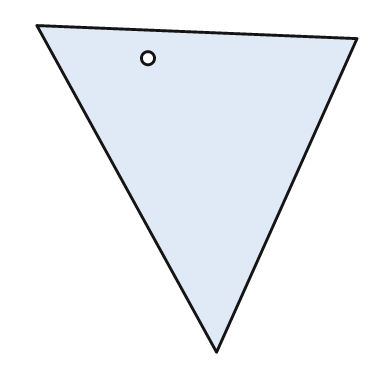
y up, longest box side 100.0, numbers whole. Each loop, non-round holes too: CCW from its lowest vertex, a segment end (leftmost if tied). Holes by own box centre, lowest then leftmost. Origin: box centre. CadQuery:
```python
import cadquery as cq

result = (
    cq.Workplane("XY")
    .moveTo(6.0, -50.0)
    .lineTo(49.0, 46.0)
    .lineTo(-49.0, 50.0)
    .close()
    .moveTo(-15.0, 40.0)
    .circle(2.0)
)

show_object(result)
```